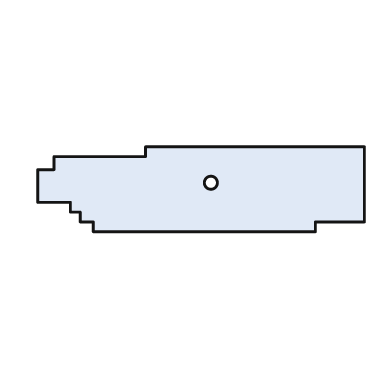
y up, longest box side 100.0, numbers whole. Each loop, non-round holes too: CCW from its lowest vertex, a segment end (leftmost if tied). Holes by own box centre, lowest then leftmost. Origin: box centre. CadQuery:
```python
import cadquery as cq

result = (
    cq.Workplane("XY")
    .moveTo(-33.0, -13.0)
    .lineTo(35.0, -13.0)
    .lineTo(35.0, -10.0)
    .lineTo(50.0, -10.0)
    .lineTo(50.0, 13.0)
    .lineTo(-17.0, 13.0)
    .lineTo(-17.0, 10.0)
    .lineTo(-45.0, 10.0)
    .lineTo(-45.0, 6.0)
    .lineTo(-50.0, 6.0)
    .lineTo(-50.0, -4.0)
    .lineTo(-40.0, -4.0)
    .lineTo(-40.0, -7.0)
    .lineTo(-37.0, -7.0)
    .lineTo(-37.0, -10.0)
    .lineTo(-33.0, -10.0)
    .close()
    .moveTo(3.0, 2.0)
    .circle(2.0)
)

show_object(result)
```